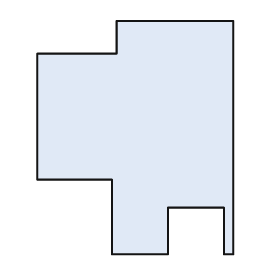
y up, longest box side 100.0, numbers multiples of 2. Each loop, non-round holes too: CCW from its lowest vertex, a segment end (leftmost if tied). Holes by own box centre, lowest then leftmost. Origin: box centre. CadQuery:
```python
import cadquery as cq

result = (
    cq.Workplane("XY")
    .moveTo(-10.0, -50.0)
    .lineTo(14.0, -50.0)
    .lineTo(14.0, -30.0)
    .lineTo(38.0, -30.0)
    .lineTo(38.0, -50.0)
    .lineTo(42.0, -50.0)
    .lineTo(42.0, 50.0)
    .lineTo(-8.0, 50.0)
    .lineTo(-8.0, 36.0)
    .lineTo(-42.0, 36.0)
    .lineTo(-42.0, -18.0)
    .lineTo(-10.0, -18.0)
    .close()
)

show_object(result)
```